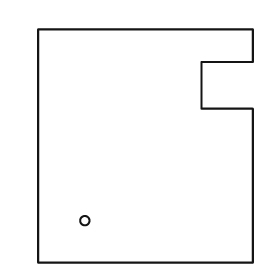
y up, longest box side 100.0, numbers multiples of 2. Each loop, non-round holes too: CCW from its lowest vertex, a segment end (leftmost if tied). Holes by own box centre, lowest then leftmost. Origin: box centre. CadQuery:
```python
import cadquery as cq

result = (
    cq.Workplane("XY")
    .moveTo(-46.0, -50.0)
    .lineTo(46.0, -50.0)
    .lineTo(46.0, 16.0)
    .lineTo(24.0, 16.0)
    .lineTo(24.0, 36.0)
    .lineTo(46.0, 36.0)
    .lineTo(46.0, 50.0)
    .lineTo(-46.0, 50.0)
    .close()
    .moveTo(-26.0, -32.0)
    .circle(2.0)
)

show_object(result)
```